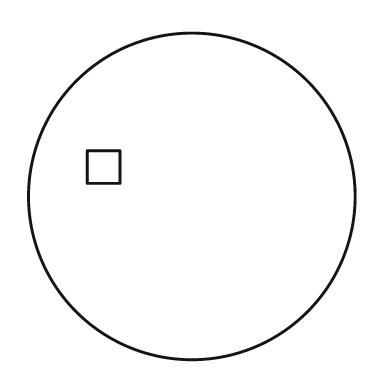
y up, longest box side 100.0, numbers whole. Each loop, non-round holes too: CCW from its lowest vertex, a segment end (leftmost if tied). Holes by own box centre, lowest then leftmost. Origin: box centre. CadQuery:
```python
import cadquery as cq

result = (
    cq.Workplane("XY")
    .moveTo(0.0, 0.0)
    .circle(50.0)
    .moveTo(-32.0, 4.0)
    .lineTo(-22.0, 4.0)
    .lineTo(-22.0, 14.0)
    .lineTo(-32.0, 14.0)
    .close()
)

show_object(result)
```